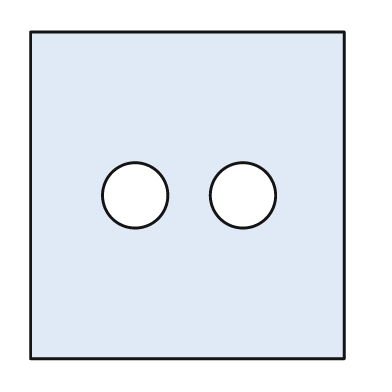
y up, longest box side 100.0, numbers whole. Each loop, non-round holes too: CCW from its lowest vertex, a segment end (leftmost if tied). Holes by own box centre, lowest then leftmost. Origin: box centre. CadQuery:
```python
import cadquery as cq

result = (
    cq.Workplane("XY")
    .moveTo(-48.0, -50.0)
    .lineTo(48.0, -50.0)
    .lineTo(48.0, 50.0)
    .lineTo(-48.0, 50.0)
    .close()
    .moveTo(-16.0, 0.0)
    .circle(10.0)
    .moveTo(17.0, 0.0)
    .circle(10.0)
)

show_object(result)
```